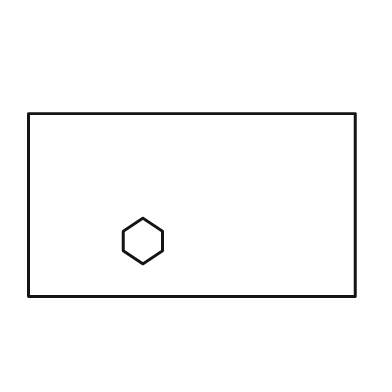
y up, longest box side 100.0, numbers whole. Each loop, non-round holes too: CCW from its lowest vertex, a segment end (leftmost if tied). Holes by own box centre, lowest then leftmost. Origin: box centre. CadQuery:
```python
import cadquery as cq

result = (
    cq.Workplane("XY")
    .moveTo(-50.0, -28.0)
    .lineTo(50.0, -28.0)
    .lineTo(50.0, 28.0)
    .lineTo(-50.0, 28.0)
    .close()
    .moveTo(-15.0, -18.0)
    .lineTo(-9.0, -14.0)
    .lineTo(-9.0, -8.0)
    .lineTo(-15.0, -4.0)
    .lineTo(-21.0, -8.0)
    .lineTo(-21.0, -14.0)
    .close()
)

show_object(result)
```